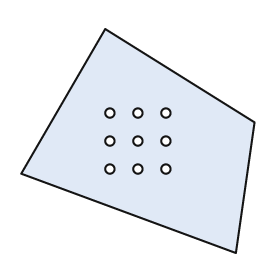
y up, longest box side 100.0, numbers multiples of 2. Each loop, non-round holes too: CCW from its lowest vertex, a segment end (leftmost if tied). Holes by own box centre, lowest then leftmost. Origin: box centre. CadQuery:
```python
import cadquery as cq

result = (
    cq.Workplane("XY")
    .moveTo(42.0, -48.0)
    .lineTo(50.0, 8.0)
    .lineTo(-14.0, 48.0)
    .lineTo(-50.0, -14.0)
    .close()
    .moveTo(-12.0, -12.0)
    .circle(2.0)
    .moveTo(0.0, -12.0)
    .circle(2.0)
    .moveTo(12.0, -12.0)
    .circle(2.0)
    .moveTo(-12.0, 0.0)
    .circle(2.0)
    .moveTo(0.0, 0.0)
    .circle(2.0)
    .moveTo(12.0, 0.0)
    .circle(2.0)
    .moveTo(-12.0, 12.0)
    .circle(2.0)
    .moveTo(0.0, 12.0)
    .circle(2.0)
    .moveTo(12.0, 12.0)
    .circle(2.0)
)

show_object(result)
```